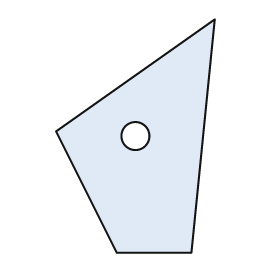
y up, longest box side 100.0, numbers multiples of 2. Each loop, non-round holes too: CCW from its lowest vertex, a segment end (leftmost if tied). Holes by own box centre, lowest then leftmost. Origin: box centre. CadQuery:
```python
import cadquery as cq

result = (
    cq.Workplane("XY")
    .moveTo(-8.0, -50.0)
    .lineTo(24.0, -50.0)
    .lineTo(34.0, 50.0)
    .lineTo(-34.0, 2.0)
    .close()
    .moveTo(0.0, 0.0)
    .circle(6.0)
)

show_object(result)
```